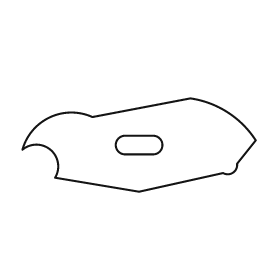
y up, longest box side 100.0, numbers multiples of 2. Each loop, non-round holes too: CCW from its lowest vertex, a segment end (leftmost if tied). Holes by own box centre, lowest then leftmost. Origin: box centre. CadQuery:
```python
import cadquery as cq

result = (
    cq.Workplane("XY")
    .moveTo(0.0, -20.0)
    .lineTo(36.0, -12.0)
    .threePointArc((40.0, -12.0), (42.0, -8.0))
    .lineTo(50.0, 2.0)
    .threePointArc((38.0, 14.0), (22.0, 20.0))
    .lineTo(-20.0, 12.0)
    .threePointArc((-38.0, 12.0), (-50.0, -2.0))
    .threePointArc((-38.0, -2.0), (-36.0, -14.0))
    .close()
    .moveTo(-6.0, -4.0)
    .lineTo(6.0, -4.0)
    .threePointArc((10.0, 0.0), (6.0, 4.0))
    .lineTo(-6.0, 4.0)
    .threePointArc((-10.0, 0.0), (-6.0, -4.0))
    .close()
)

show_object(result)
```